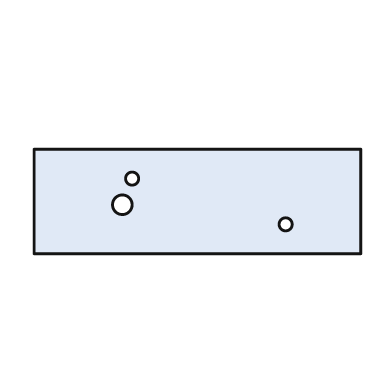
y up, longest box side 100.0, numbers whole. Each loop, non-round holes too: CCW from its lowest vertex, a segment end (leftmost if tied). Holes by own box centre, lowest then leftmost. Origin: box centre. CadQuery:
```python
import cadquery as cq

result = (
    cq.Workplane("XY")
    .moveTo(-50.0, -16.0)
    .lineTo(50.0, -16.0)
    .lineTo(50.0, 16.0)
    .lineTo(-50.0, 16.0)
    .close()
    .moveTo(27.0, -7.0)
    .circle(2.0)
    .moveTo(-23.0, -1.0)
    .circle(3.0)
    .moveTo(-20.0, 7.0)
    .circle(2.0)
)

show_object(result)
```